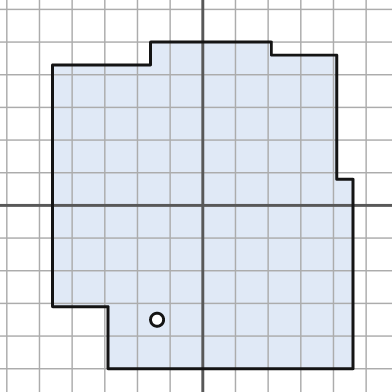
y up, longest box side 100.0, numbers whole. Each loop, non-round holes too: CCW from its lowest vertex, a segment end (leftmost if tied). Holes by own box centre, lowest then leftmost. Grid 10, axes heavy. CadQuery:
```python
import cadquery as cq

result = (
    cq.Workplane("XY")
    .moveTo(-29.0, -50.0)
    .lineTo(46.0, -50.0)
    .lineTo(46.0, 8.0)
    .lineTo(41.0, 8.0)
    .lineTo(41.0, 46.0)
    .lineTo(21.0, 46.0)
    .lineTo(21.0, 50.0)
    .lineTo(-16.0, 50.0)
    .lineTo(-16.0, 43.0)
    .lineTo(-46.0, 43.0)
    .lineTo(-46.0, -31.0)
    .lineTo(-29.0, -31.0)
    .close()
    .moveTo(-14.0, -35.0)
    .circle(2.0)
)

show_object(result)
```